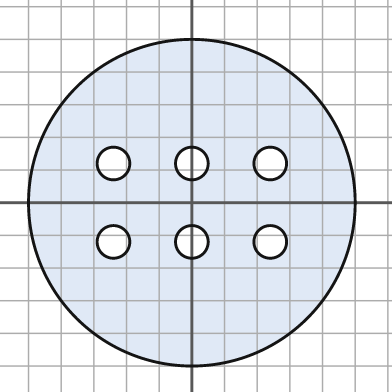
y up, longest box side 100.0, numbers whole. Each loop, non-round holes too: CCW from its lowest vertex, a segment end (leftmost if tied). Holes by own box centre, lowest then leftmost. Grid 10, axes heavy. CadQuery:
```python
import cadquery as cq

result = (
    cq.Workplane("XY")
    .moveTo(0.0, 0.0)
    .circle(50.0)
    .moveTo(-24.0, -12.0)
    .circle(5.0)
    .moveTo(0.0, -12.0)
    .circle(5.0)
    .moveTo(24.0, -12.0)
    .circle(5.0)
    .moveTo(-24.0, 12.0)
    .circle(5.0)
    .moveTo(0.0, 12.0)
    .circle(5.0)
    .moveTo(24.0, 12.0)
    .circle(5.0)
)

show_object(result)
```